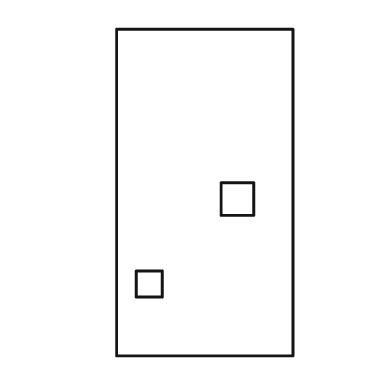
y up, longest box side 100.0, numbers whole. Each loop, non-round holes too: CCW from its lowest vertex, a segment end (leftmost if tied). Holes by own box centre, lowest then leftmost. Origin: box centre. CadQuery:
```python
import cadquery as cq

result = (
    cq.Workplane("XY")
    .moveTo(-27.0, -50.0)
    .lineTo(27.0, -50.0)
    .lineTo(27.0, 50.0)
    .lineTo(-27.0, 50.0)
    .close()
    .moveTo(-21.0, -32.0)
    .lineTo(-13.0, -32.0)
    .lineTo(-13.0, -24.0)
    .lineTo(-21.0, -24.0)
    .close()
    .moveTo(5.0, -7.0)
    .lineTo(15.0, -7.0)
    .lineTo(15.0, 3.0)
    .lineTo(5.0, 3.0)
    .close()
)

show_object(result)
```